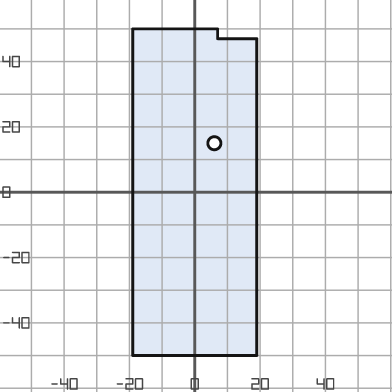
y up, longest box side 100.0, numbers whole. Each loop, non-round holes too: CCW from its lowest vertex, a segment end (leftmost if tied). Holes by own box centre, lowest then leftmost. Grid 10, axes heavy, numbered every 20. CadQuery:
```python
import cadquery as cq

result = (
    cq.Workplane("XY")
    .moveTo(-19.0, -50.0)
    .lineTo(19.0, -50.0)
    .lineTo(19.0, 47.0)
    .lineTo(7.0, 47.0)
    .lineTo(7.0, 50.0)
    .lineTo(-19.0, 50.0)
    .close()
    .moveTo(6.0, 15.0)
    .circle(2.0)
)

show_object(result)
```